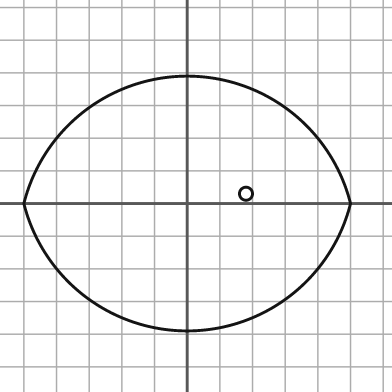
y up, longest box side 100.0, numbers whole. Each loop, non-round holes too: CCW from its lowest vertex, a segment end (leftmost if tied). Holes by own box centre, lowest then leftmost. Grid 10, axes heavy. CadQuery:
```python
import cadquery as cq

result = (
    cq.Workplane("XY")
    .moveTo(-50.0, 0.0)
    .threePointArc((0.0, -39.0), (50.0, 0.0))
    .threePointArc((0.0, 39.0), (-50.0, 0.0))
    .close()
    .moveTo(18.0, 3.0)
    .circle(2.0)
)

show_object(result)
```